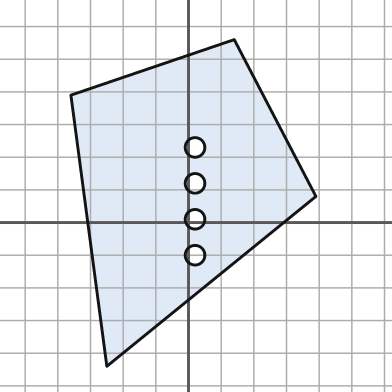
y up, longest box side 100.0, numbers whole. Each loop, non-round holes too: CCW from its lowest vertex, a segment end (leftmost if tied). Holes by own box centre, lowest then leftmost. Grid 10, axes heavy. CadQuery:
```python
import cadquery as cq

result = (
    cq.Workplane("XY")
    .moveTo(-25.0, -44.0)
    .lineTo(39.0, 8.0)
    .lineTo(14.0, 56.0)
    .lineTo(-36.0, 39.0)
    .close()
    .moveTo(2.0, -10.0)
    .circle(3.0)
    .moveTo(2.0, 1.0)
    .circle(3.0)
    .moveTo(2.0, 12.0)
    .circle(3.0)
    .moveTo(2.0, 23.0)
    .circle(3.0)
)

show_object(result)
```